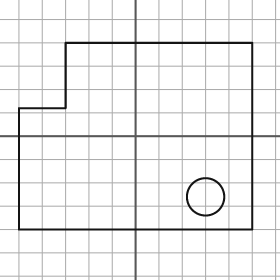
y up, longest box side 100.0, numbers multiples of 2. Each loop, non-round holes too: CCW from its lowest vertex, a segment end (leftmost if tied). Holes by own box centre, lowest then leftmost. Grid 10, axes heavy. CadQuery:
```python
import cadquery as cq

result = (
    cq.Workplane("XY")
    .moveTo(-50.0, -40.0)
    .lineTo(50.0, -40.0)
    .lineTo(50.0, 40.0)
    .lineTo(-30.0, 40.0)
    .lineTo(-30.0, 12.0)
    .lineTo(-50.0, 12.0)
    .close()
    .moveTo(30.0, -26.0)
    .circle(8.0)
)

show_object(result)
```